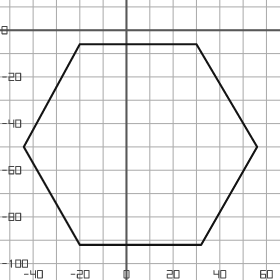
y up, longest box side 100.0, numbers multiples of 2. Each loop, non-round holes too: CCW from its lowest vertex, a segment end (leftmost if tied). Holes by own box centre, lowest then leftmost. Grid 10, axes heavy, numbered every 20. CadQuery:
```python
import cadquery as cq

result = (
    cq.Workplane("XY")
    .moveTo(-20.0, -92.0)
    .lineTo(32.0, -92.0)
    .lineTo(56.0, -50.0)
    .lineTo(30.0, -6.0)
    .lineTo(-20.0, -6.0)
    .lineTo(-44.0, -50.0)
    .close()
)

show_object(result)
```